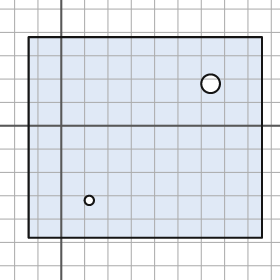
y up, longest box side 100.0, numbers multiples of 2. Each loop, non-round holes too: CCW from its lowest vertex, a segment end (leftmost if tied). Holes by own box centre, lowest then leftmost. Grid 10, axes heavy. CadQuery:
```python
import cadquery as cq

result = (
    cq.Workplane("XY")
    .moveTo(-14.0, -48.0)
    .lineTo(86.0, -48.0)
    .lineTo(86.0, 38.0)
    .lineTo(-14.0, 38.0)
    .close()
    .moveTo(12.0, -32.0)
    .circle(2.0)
    .moveTo(64.0, 18.0)
    .circle(4.0)
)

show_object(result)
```